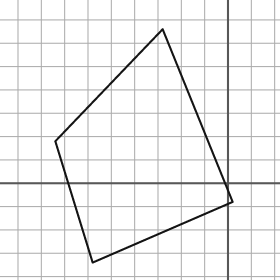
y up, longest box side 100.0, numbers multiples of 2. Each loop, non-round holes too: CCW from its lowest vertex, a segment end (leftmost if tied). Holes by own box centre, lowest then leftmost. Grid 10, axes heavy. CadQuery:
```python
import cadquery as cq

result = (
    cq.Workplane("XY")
    .moveTo(-58.0, -34.0)
    .lineTo(2.0, -8.0)
    .lineTo(-28.0, 66.0)
    .lineTo(-74.0, 18.0)
    .close()
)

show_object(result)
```